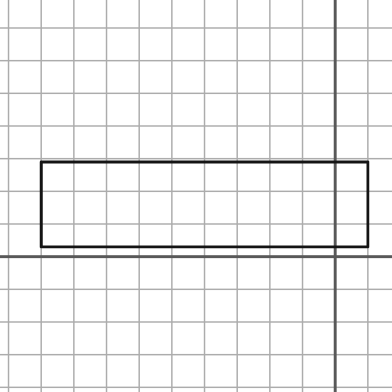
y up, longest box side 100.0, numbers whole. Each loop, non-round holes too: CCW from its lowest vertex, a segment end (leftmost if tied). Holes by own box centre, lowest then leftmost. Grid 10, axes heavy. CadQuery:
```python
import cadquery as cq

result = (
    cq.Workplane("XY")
    .moveTo(-90.0, 3.0)
    .lineTo(10.0, 3.0)
    .lineTo(10.0, 29.0)
    .lineTo(-90.0, 29.0)
    .close()
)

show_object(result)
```